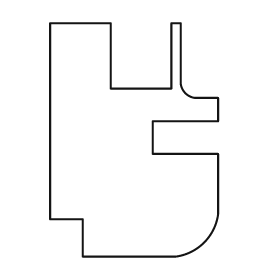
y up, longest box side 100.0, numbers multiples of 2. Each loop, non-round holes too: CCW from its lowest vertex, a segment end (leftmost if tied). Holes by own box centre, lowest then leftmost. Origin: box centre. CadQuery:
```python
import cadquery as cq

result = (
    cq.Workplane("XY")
    .moveTo(-22.0, -50.0)
    .lineTo(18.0, -50.0)
    .threePointArc((30.0, -44.0), (36.0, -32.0))
    .lineTo(36.0, -6.0)
    .lineTo(8.0, -6.0)
    .lineTo(8.0, 8.0)
    .lineTo(36.0, 8.0)
    .lineTo(36.0, 18.0)
    .lineTo(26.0, 18.0)
    .threePointArc((22.0, 20.0), (20.0, 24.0))
    .lineTo(20.0, 50.0)
    .lineTo(16.0, 50.0)
    .lineTo(16.0, 22.0)
    .lineTo(-10.0, 22.0)
    .lineTo(-10.0, 50.0)
    .lineTo(-36.0, 50.0)
    .lineTo(-36.0, -34.0)
    .lineTo(-22.0, -34.0)
    .close()
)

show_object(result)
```